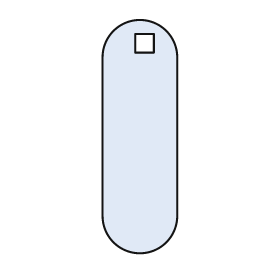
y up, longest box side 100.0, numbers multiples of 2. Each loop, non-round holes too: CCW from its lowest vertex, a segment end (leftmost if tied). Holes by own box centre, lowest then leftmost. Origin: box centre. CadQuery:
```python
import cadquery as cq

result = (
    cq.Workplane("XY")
    .moveTo(-16.0, -34.0)
    .threePointArc((0.0, -50.0), (16.0, -34.0))
    .lineTo(16.0, 34.0)
    .threePointArc((0.0, 50.0), (-16.0, 34.0))
    .close()
    .moveTo(-2.0, 36.0)
    .lineTo(6.0, 36.0)
    .lineTo(6.0, 44.0)
    .lineTo(-2.0, 44.0)
    .close()
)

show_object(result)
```